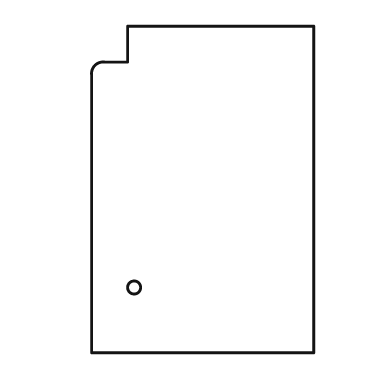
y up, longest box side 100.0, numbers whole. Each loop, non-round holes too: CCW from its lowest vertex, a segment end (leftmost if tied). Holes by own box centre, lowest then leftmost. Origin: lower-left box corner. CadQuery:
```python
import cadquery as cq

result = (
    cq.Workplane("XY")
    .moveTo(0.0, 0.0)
    .lineTo(68.0, 0.0)
    .lineTo(68.0, 100.0)
    .lineTo(11.0, 100.0)
    .lineTo(11.0, 89.0)
    .lineTo(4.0, 89.0)
    .threePointArc((1.0, 88.0), (0.0, 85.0))
    .close()
    .moveTo(13.0, 20.0)
    .circle(2.0)
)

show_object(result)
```